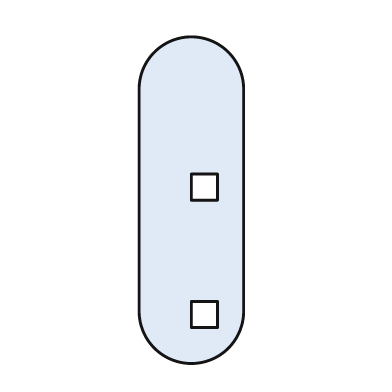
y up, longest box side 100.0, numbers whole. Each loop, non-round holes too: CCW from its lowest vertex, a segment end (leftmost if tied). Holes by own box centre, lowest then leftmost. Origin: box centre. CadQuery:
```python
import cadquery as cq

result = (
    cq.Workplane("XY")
    .moveTo(-16.0, -34.0)
    .threePointArc((0.0, -50.0), (16.0, -34.0))
    .lineTo(16.0, 34.0)
    .threePointArc((0.0, 50.0), (-16.0, 34.0))
    .close()
    .moveTo(0.0, -39.0)
    .lineTo(8.0, -39.0)
    .lineTo(8.0, -31.0)
    .lineTo(0.0, -31.0)
    .close()
    .moveTo(0.0, 0.0)
    .lineTo(8.0, 0.0)
    .lineTo(8.0, 8.0)
    .lineTo(0.0, 8.0)
    .close()
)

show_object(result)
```